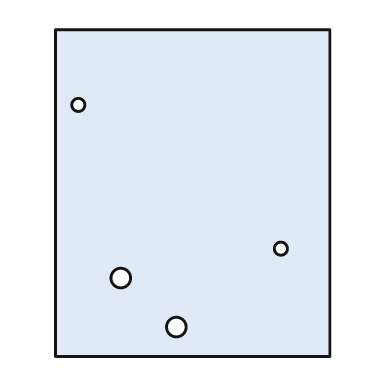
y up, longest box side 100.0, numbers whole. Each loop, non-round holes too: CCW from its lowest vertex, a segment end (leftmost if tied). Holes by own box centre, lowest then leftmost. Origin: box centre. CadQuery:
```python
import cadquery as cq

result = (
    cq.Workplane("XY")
    .moveTo(-42.0, -50.0)
    .lineTo(42.0, -50.0)
    .lineTo(42.0, 50.0)
    .lineTo(-42.0, 50.0)
    .close()
    .moveTo(-5.0, -41.0)
    .circle(3.0)
    .moveTo(-22.0, -26.0)
    .circle(3.0)
    .moveTo(27.0, -17.0)
    .circle(2.0)
    .moveTo(-35.0, 27.0)
    .circle(2.0)
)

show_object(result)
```